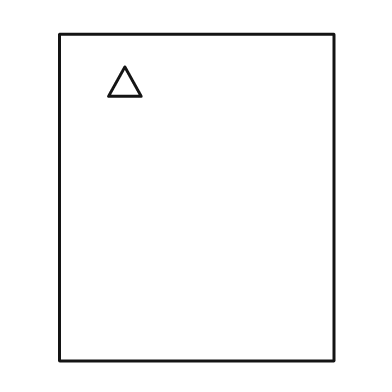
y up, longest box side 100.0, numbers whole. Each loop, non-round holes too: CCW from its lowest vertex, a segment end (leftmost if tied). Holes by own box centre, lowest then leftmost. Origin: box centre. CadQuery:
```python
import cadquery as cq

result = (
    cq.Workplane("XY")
    .moveTo(-42.0, -50.0)
    .lineTo(42.0, -50.0)
    .lineTo(42.0, 50.0)
    .lineTo(-42.0, 50.0)
    .close()
    .moveTo(-27.0, 31.0)
    .lineTo(-17.0, 31.0)
    .lineTo(-22.0, 40.0)
    .close()
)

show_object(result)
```